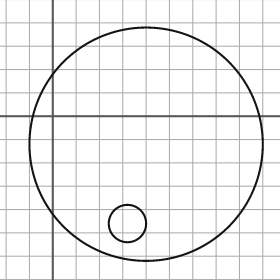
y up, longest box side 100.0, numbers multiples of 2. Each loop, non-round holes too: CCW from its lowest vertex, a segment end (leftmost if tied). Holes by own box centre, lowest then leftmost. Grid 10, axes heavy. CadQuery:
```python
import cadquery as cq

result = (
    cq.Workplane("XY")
    .moveTo(40.0, -12.0)
    .circle(50.0)
    .moveTo(32.0, -46.0)
    .circle(8.0)
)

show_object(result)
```